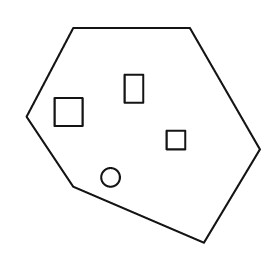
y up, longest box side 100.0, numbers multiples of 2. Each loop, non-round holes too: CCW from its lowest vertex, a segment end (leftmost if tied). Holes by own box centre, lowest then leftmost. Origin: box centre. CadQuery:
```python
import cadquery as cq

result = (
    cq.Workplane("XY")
    .moveTo(26.0, -46.0)
    .lineTo(50.0, -6.0)
    .lineTo(20.0, 46.0)
    .lineTo(-30.0, 46.0)
    .lineTo(-50.0, 8.0)
    .lineTo(-30.0, -22.0)
    .close()
    .moveTo(-14.0, -18.0)
    .circle(4.0)
    .moveTo(10.0, -6.0)
    .lineTo(18.0, -6.0)
    .lineTo(18.0, 2.0)
    .lineTo(10.0, 2.0)
    .close()
    .moveTo(-38.0, 4.0)
    .lineTo(-26.0, 4.0)
    .lineTo(-26.0, 16.0)
    .lineTo(-38.0, 16.0)
    .close()
    .moveTo(-8.0, 14.0)
    .lineTo(0.0, 14.0)
    .lineTo(0.0, 26.0)
    .lineTo(-8.0, 26.0)
    .close()
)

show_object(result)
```